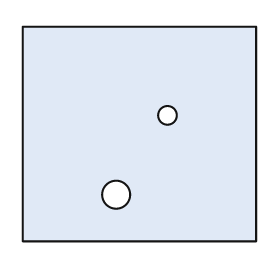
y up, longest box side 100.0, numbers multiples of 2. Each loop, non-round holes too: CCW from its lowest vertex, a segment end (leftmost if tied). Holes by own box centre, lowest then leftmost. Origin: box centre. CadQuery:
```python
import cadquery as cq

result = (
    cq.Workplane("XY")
    .moveTo(-50.0, -46.0)
    .lineTo(50.0, -46.0)
    .lineTo(50.0, 46.0)
    .lineTo(-50.0, 46.0)
    .close()
    .moveTo(-10.0, -26.0)
    .circle(6.0)
    .moveTo(12.0, 8.0)
    .circle(4.0)
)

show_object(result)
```